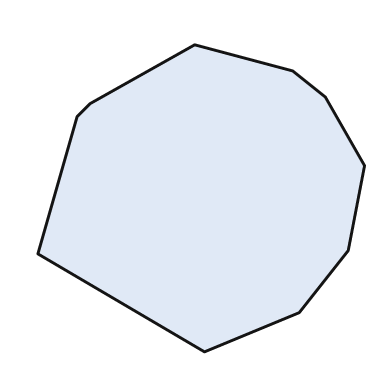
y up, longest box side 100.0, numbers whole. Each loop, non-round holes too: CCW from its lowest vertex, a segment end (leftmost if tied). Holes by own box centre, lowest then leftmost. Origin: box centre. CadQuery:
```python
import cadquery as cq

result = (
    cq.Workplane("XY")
    .moveTo(1.0, -47.0)
    .lineTo(30.0, -35.0)
    .lineTo(45.0, -16.0)
    .lineTo(50.0, 10.0)
    .lineTo(38.0, 31.0)
    .lineTo(28.0, 39.0)
    .lineTo(-2.0, 47.0)
    .lineTo(-34.0, 29.0)
    .lineTo(-38.0, 25.0)
    .lineTo(-50.0, -17.0)
    .close()
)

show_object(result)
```